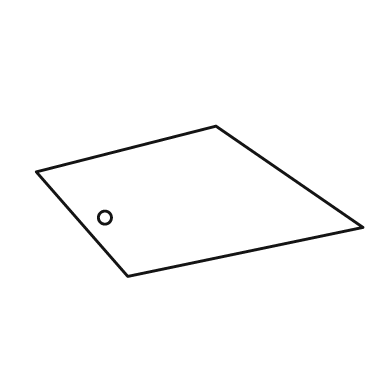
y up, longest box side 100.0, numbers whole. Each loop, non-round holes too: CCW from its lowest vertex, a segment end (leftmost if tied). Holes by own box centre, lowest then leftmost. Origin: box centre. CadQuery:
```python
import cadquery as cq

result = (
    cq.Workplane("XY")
    .moveTo(-22.0, -23.0)
    .lineTo(50.0, -8.0)
    .lineTo(5.0, 23.0)
    .lineTo(-50.0, 9.0)
    .close()
    .moveTo(-29.0, -5.0)
    .circle(2.0)
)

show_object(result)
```